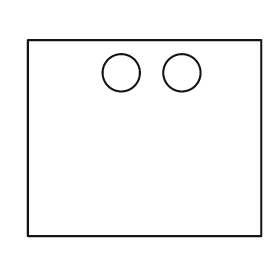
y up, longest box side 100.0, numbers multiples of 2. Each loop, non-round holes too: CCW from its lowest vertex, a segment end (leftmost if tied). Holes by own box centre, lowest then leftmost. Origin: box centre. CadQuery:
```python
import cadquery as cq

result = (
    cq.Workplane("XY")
    .moveTo(-50.0, -42.0)
    .lineTo(50.0, -42.0)
    .lineTo(50.0, 42.0)
    .lineTo(-50.0, 42.0)
    .close()
    .moveTo(-10.0, 28.0)
    .circle(8.0)
    .moveTo(16.0, 28.0)
    .circle(8.0)
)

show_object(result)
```